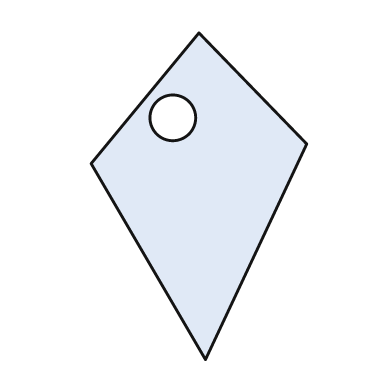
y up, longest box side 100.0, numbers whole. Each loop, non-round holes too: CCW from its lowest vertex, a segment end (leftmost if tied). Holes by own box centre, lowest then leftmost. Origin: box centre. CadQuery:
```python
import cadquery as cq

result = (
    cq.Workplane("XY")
    .moveTo(2.0, -50.0)
    .lineTo(33.0, 16.0)
    .lineTo(0.0, 50.0)
    .lineTo(-33.0, 10.0)
    .close()
    .moveTo(-8.0, 24.0)
    .circle(7.0)
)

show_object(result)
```